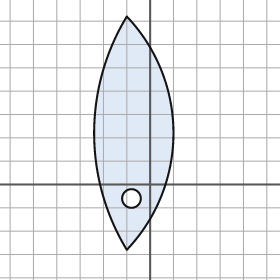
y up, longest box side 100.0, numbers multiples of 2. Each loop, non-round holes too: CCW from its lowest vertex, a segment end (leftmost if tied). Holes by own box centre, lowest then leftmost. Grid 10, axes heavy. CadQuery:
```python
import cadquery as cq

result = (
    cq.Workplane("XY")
    .moveTo(-10.0, -28.0)
    .threePointArc((10.0, 22.0), (-10.0, 72.0))
    .threePointArc((-24.0, 22.0), (-10.0, -28.0))
    .close()
    .moveTo(-8.0, -6.0)
    .circle(4.0)
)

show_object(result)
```